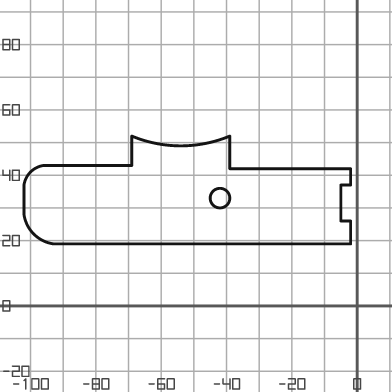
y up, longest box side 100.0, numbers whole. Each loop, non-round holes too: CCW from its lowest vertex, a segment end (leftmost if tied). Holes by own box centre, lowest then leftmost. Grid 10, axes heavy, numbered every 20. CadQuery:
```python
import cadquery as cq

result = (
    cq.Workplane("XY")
    .moveTo(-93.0, 19.0)
    .lineTo(-2.0, 19.0)
    .lineTo(-2.0, 26.0)
    .lineTo(-5.0, 26.0)
    .lineTo(-5.0, 37.0)
    .lineTo(-2.0, 37.0)
    .lineTo(-2.0, 42.0)
    .lineTo(-39.0, 42.0)
    .lineTo(-39.0, 52.0)
    .threePointArc((-54.0, 49.0), (-69.0, 52.0))
    .lineTo(-69.0, 43.0)
    .lineTo(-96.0, 43.0)
    .threePointArc((-100.0, 41.0), (-102.0, 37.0))
    .lineTo(-102.0, 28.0)
    .threePointArc((-99.0, 22.0), (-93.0, 19.0))
    .close()
    .moveTo(-42.0, 33.0)
    .circle(3.0)
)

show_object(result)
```